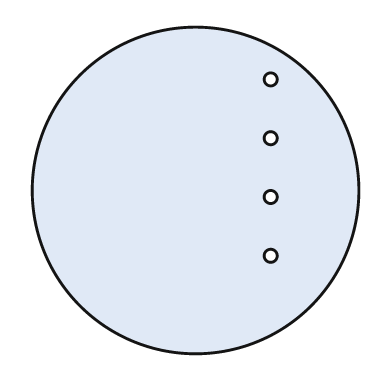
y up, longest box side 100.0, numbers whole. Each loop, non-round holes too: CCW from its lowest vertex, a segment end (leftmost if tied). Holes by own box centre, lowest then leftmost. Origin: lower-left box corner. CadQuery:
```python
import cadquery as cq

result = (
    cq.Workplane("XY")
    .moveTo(50.0, 50.0)
    .circle(50.0)
    .moveTo(73.0, 30.0)
    .circle(2.0)
    .moveTo(73.0, 48.0)
    .circle(2.0)
    .moveTo(73.0, 66.0)
    .circle(2.0)
    .moveTo(73.0, 84.0)
    .circle(2.0)
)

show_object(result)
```